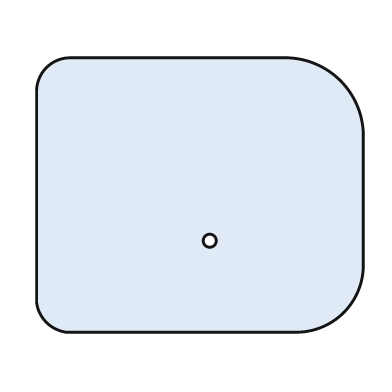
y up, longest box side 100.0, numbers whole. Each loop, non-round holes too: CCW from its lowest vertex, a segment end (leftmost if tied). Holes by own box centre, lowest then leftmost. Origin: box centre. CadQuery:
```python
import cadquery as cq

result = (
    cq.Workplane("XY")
    .moveTo(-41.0, -42.0)
    .lineTo(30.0, -42.0)
    .threePointArc((44.0, -36.0), (50.0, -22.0))
    .lineTo(50.0, 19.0)
    .threePointArc((43.0, 35.0), (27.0, 42.0))
    .lineTo(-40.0, 42.0)
    .threePointArc((-47.0, 39.0), (-50.0, 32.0))
    .lineTo(-50.0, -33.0)
    .threePointArc((-47.0, -39.0), (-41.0, -42.0))
    .close()
    .moveTo(3.0, -14.0)
    .circle(2.0)
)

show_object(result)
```